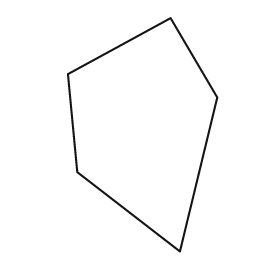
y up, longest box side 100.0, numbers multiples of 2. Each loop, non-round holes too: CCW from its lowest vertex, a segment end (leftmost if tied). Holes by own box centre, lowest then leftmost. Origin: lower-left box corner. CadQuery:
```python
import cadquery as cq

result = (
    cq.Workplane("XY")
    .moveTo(48.0, 0.0)
    .lineTo(64.0, 66.0)
    .lineTo(44.0, 100.0)
    .lineTo(0.0, 76.0)
    .lineTo(4.0, 34.0)
    .close()
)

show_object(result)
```